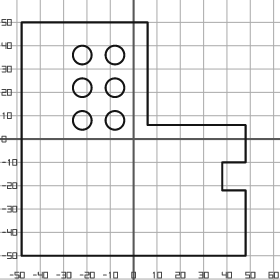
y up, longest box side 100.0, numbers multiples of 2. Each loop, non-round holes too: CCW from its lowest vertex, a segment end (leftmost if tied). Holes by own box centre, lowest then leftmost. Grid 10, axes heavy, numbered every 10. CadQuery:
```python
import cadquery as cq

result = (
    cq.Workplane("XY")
    .moveTo(-48.0, -50.0)
    .lineTo(48.0, -50.0)
    .lineTo(48.0, -22.0)
    .lineTo(38.0, -22.0)
    .lineTo(38.0, -10.0)
    .lineTo(48.0, -10.0)
    .lineTo(48.0, 6.0)
    .lineTo(6.0, 6.0)
    .lineTo(6.0, 50.0)
    .lineTo(-48.0, 50.0)
    .close()
    .moveTo(-22.0, 8.0)
    .circle(4.0)
    .moveTo(-8.0, 8.0)
    .circle(4.0)
    .moveTo(-22.0, 22.0)
    .circle(4.0)
    .moveTo(-8.0, 22.0)
    .circle(4.0)
    .moveTo(-22.0, 36.0)
    .circle(4.0)
    .moveTo(-8.0, 36.0)
    .circle(4.0)
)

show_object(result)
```